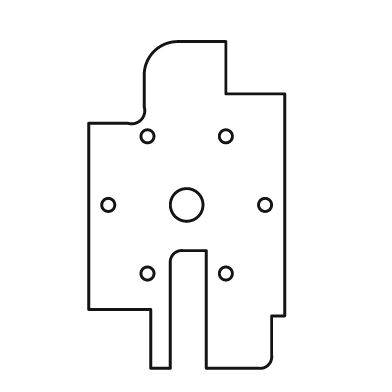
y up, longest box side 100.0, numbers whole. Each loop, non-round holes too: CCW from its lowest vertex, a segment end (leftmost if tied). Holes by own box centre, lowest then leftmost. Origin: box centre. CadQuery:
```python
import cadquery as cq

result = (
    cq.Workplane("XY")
    .moveTo(-11.0, -50.0)
    .lineTo(-5.0, -50.0)
    .lineTo(-5.0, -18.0)
    .threePointArc((-4.0, -15.0), (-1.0, -14.0))
    .lineTo(6.0, -14.0)
    .lineTo(6.0, -50.0)
    .lineTo(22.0, -50.0)
    .threePointArc((25.0, -49.0), (26.0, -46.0))
    .lineTo(26.0, -34.0)
    .lineTo(30.0, -34.0)
    .lineTo(30.0, 34.0)
    .lineTo(12.0, 34.0)
    .lineTo(12.0, 50.0)
    .lineTo(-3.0, 50.0)
    .threePointArc((-10.0, 47.0), (-13.0, 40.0))
    .lineTo(-13.0, 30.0)
    .threePointArc((-14.0, 26.0), (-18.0, 25.0))
    .lineTo(-30.0, 25.0)
    .lineTo(-30.0, -32.0)
    .lineTo(-11.0, -32.0)
    .close()
    .moveTo(-12.0, -21.0)
    .circle(2.0)
    .moveTo(12.0, -21.0)
    .circle(2.0)
    .moveTo(-24.0, 0.0)
    .circle(2.0)
    .moveTo(0.0, 0.0)
    .circle(5.0)
    .moveTo(24.0, 0.0)
    .circle(2.0)
    .moveTo(-12.0, 21.0)
    .circle(2.0)
    .moveTo(12.0, 21.0)
    .circle(2.0)
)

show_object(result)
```